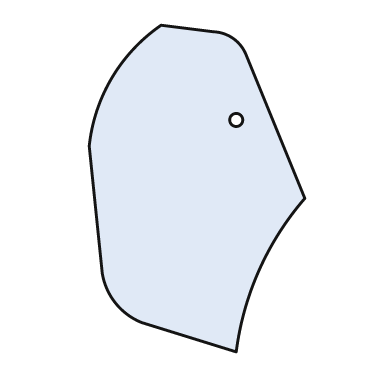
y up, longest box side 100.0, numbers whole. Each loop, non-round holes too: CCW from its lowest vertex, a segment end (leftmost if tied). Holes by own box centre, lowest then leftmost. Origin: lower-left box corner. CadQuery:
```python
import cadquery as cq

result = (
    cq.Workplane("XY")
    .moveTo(45.0, 0.0)
    .threePointArc((52.0, 25.0), (66.0, 47.0))
    .lineTo(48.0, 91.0)
    .threePointArc((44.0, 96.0), (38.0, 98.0))
    .lineTo(22.0, 100.0)
    .threePointArc((7.0, 84.0), (0.0, 63.0))
    .lineTo(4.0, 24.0)
    .threePointArc((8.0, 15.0), (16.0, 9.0))
    .close()
    .moveTo(45.0, 71.0)
    .circle(2.0)
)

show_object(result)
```